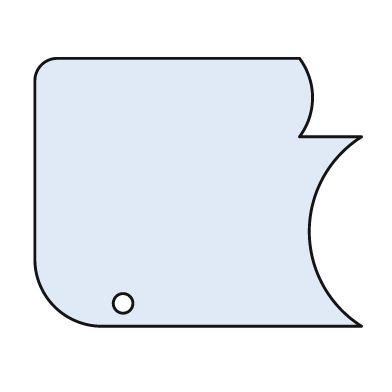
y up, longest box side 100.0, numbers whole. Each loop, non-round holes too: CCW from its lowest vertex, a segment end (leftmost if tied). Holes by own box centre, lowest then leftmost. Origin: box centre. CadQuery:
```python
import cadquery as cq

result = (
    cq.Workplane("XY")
    .moveTo(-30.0, -41.0)
    .lineTo(50.0, -41.0)
    .threePointArc((34.0, -12.0), (50.0, 17.0))
    .lineTo(31.0, 17.0)
    .threePointArc((35.0, 29.0), (31.0, 41.0))
    .lineTo(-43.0, 41.0)
    .threePointArc((-48.0, 39.0), (-50.0, 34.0))
    .lineTo(-50.0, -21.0)
    .threePointArc((-44.0, -35.0), (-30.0, -41.0))
    .close()
    .moveTo(-23.0, -34.0)
    .circle(3.0)
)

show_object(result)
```